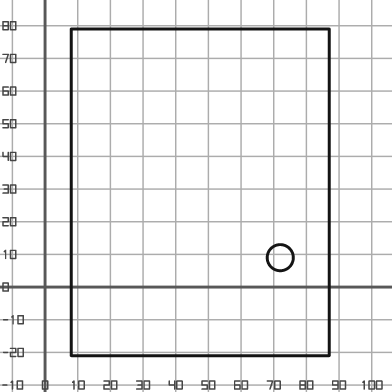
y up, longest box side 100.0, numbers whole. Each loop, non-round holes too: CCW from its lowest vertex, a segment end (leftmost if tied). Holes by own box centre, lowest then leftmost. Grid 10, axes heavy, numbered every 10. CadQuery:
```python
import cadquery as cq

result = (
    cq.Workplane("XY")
    .moveTo(8.0, -21.0)
    .lineTo(87.0, -21.0)
    .lineTo(87.0, 79.0)
    .lineTo(8.0, 79.0)
    .close()
    .moveTo(72.0, 9.0)
    .circle(4.0)
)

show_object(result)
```